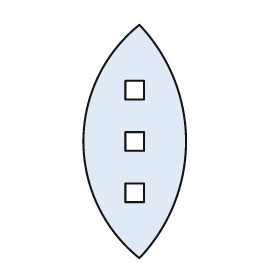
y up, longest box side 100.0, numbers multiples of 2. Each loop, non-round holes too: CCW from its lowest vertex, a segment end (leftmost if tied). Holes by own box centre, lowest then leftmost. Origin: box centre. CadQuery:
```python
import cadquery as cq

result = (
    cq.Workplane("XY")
    .moveTo(2.0, -50.0)
    .threePointArc((22.0, 0.0), (2.0, 50.0))
    .threePointArc((-22.0, 0.0), (2.0, -50.0))
    .close()
    .moveTo(-4.0, -26.0)
    .lineTo(4.0, -26.0)
    .lineTo(4.0, -18.0)
    .lineTo(-4.0, -18.0)
    .close()
    .moveTo(-4.0, -4.0)
    .lineTo(4.0, -4.0)
    .lineTo(4.0, 4.0)
    .lineTo(-4.0, 4.0)
    .close()
    .moveTo(-4.0, 18.0)
    .lineTo(4.0, 18.0)
    .lineTo(4.0, 26.0)
    .lineTo(-4.0, 26.0)
    .close()
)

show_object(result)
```